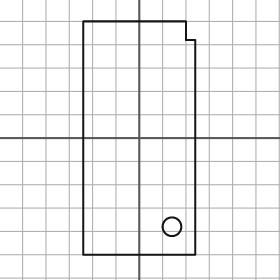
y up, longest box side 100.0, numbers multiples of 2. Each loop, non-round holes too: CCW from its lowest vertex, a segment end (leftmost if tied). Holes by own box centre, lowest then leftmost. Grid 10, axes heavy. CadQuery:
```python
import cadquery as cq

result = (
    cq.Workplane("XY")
    .moveTo(-24.0, -50.0)
    .lineTo(24.0, -50.0)
    .lineTo(24.0, 42.0)
    .lineTo(20.0, 42.0)
    .lineTo(20.0, 50.0)
    .lineTo(-24.0, 50.0)
    .close()
    .moveTo(14.0, -38.0)
    .circle(4.0)
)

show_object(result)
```